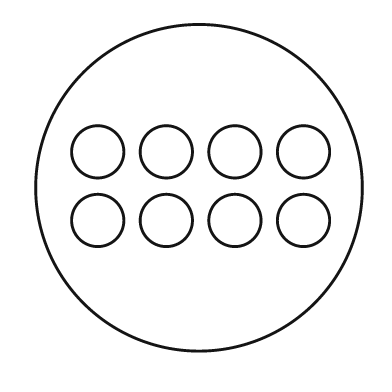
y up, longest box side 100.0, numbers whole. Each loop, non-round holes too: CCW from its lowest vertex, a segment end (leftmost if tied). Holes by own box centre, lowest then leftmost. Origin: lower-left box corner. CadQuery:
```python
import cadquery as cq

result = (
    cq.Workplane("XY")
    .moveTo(50.0, 50.0)
    .circle(50.0)
    .moveTo(19.0, 40.0)
    .circle(8.0)
    .moveTo(40.0, 40.0)
    .circle(8.0)
    .moveTo(61.0, 40.0)
    .circle(8.0)
    .moveTo(82.0, 40.0)
    .circle(8.0)
    .moveTo(19.0, 61.0)
    .circle(8.0)
    .moveTo(40.0, 61.0)
    .circle(8.0)
    .moveTo(61.0, 61.0)
    .circle(8.0)
    .moveTo(82.0, 61.0)
    .circle(8.0)
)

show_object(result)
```